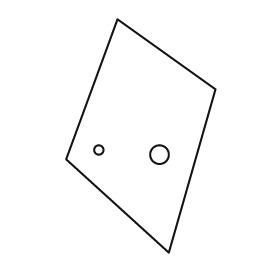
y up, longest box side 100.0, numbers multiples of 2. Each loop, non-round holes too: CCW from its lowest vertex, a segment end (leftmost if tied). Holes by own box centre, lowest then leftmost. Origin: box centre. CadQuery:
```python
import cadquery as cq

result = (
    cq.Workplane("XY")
    .moveTo(12.0, -50.0)
    .lineTo(32.0, 20.0)
    .lineTo(-10.0, 50.0)
    .lineTo(-32.0, -10.0)
    .close()
    .moveTo(8.0, -8.0)
    .circle(4.0)
    .moveTo(-18.0, -6.0)
    .circle(2.0)
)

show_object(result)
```